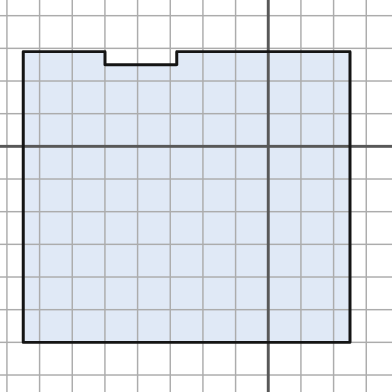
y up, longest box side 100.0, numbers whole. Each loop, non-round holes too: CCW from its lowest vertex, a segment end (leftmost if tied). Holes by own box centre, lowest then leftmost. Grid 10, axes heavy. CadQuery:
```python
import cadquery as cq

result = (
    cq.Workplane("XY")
    .moveTo(-75.0, -60.0)
    .lineTo(25.0, -60.0)
    .lineTo(25.0, 29.0)
    .lineTo(-28.0, 29.0)
    .lineTo(-28.0, 25.0)
    .lineTo(-50.0, 25.0)
    .lineTo(-50.0, 29.0)
    .lineTo(-75.0, 29.0)
    .close()
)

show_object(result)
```